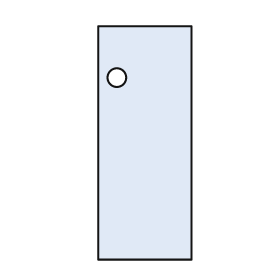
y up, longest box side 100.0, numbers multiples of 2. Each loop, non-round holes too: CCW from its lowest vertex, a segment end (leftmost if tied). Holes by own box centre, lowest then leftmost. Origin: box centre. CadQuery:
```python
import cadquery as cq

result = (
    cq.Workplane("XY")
    .moveTo(-20.0, -50.0)
    .lineTo(20.0, -50.0)
    .lineTo(20.0, 50.0)
    .lineTo(-20.0, 50.0)
    .close()
    .moveTo(-12.0, 28.0)
    .circle(4.0)
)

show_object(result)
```